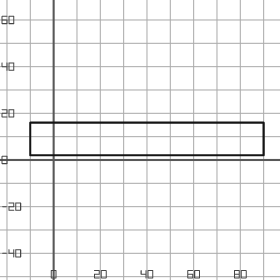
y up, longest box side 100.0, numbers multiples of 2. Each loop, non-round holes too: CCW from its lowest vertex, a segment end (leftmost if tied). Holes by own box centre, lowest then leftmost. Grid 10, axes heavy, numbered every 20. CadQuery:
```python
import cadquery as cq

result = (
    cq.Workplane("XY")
    .moveTo(-10.0, 2.0)
    .lineTo(90.0, 2.0)
    .lineTo(90.0, 16.0)
    .lineTo(-10.0, 16.0)
    .close()
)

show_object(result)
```